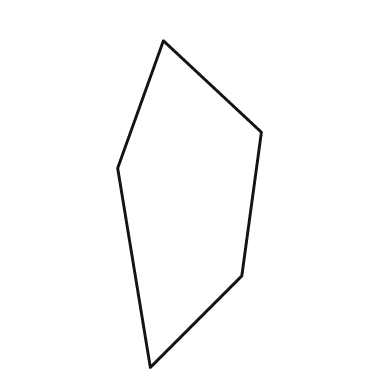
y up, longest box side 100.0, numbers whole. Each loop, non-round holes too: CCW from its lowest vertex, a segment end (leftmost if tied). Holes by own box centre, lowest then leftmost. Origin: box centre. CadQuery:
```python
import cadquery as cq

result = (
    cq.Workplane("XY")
    .moveTo(-12.0, -50.0)
    .lineTo(16.0, -22.0)
    .lineTo(22.0, 22.0)
    .lineTo(-8.0, 50.0)
    .lineTo(-22.0, 11.0)
    .close()
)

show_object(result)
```